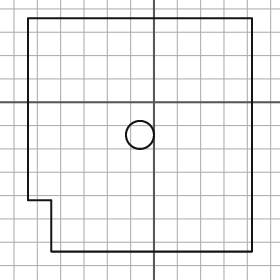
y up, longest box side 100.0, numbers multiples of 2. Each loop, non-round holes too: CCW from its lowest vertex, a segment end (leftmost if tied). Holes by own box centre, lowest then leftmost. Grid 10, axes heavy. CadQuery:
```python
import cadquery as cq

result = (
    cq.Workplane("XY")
    .moveTo(-44.0, -64.0)
    .lineTo(42.0, -64.0)
    .lineTo(42.0, 36.0)
    .lineTo(-54.0, 36.0)
    .lineTo(-54.0, -42.0)
    .lineTo(-44.0, -42.0)
    .close()
    .moveTo(-6.0, -14.0)
    .circle(6.0)
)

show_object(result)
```